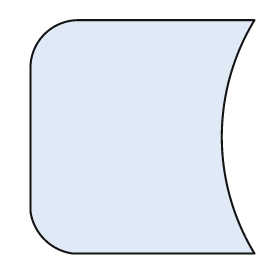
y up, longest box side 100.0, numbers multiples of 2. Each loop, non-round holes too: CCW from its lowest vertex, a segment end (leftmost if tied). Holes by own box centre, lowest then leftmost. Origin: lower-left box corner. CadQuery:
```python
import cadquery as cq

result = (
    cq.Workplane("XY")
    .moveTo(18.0, 0.0)
    .lineTo(96.0, 0.0)
    .threePointArc((82.0, 50.0), (96.0, 100.0))
    .lineTo(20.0, 100.0)
    .threePointArc((6.0, 94.0), (0.0, 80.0))
    .lineTo(0.0, 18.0)
    .threePointArc((6.0, 6.0), (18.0, 0.0))
    .close()
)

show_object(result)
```